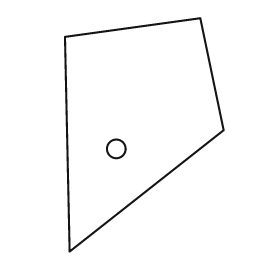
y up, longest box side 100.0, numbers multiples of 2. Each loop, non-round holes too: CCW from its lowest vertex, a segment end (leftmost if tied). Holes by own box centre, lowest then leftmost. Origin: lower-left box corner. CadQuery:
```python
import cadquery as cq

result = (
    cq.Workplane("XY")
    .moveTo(2.0, 0.0)
    .lineTo(68.0, 52.0)
    .lineTo(58.0, 100.0)
    .lineTo(0.0, 92.0)
    .close()
    .moveTo(22.0, 44.0)
    .circle(4.0)
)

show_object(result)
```